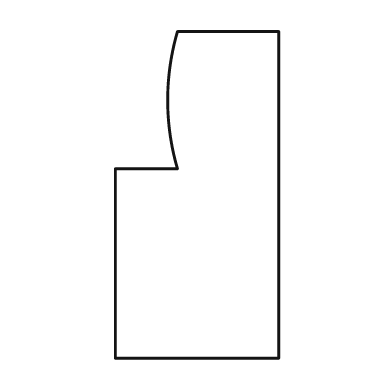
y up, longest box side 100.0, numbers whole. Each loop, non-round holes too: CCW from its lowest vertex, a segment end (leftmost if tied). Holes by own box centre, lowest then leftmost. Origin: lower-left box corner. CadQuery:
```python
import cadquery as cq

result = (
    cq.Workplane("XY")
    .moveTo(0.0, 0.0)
    .lineTo(50.0, 0.0)
    .lineTo(50.0, 100.0)
    .lineTo(19.0, 100.0)
    .threePointArc((16.0, 79.0), (19.0, 58.0))
    .lineTo(0.0, 58.0)
    .close()
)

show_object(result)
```